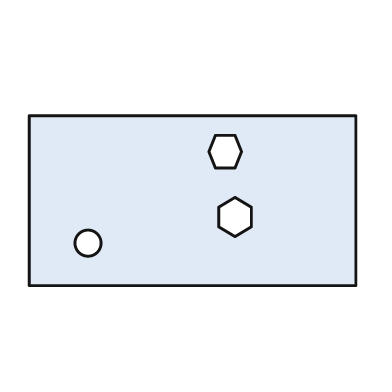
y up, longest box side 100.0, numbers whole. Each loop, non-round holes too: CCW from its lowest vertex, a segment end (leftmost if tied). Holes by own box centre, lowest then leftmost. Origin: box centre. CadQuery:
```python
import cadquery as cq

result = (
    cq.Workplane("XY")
    .moveTo(-50.0, -26.0)
    .lineTo(50.0, -26.0)
    .lineTo(50.0, 26.0)
    .lineTo(-50.0, 26.0)
    .close()
    .moveTo(-32.0, -13.0)
    .circle(4.0)
    .moveTo(13.0, -11.0)
    .lineTo(18.0, -8.0)
    .lineTo(18.0, -2.0)
    .lineTo(13.0, 1.0)
    .lineTo(8.0, -2.0)
    .lineTo(8.0, -8.0)
    .close()
    .moveTo(7.0, 10.0)
    .lineTo(13.0, 10.0)
    .lineTo(15.0, 15.0)
    .lineTo(13.0, 20.0)
    .lineTo(7.0, 20.0)
    .lineTo(5.0, 15.0)
    .close()
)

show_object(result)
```